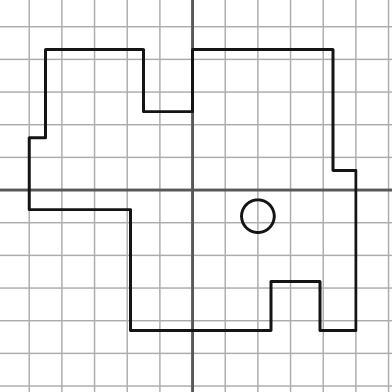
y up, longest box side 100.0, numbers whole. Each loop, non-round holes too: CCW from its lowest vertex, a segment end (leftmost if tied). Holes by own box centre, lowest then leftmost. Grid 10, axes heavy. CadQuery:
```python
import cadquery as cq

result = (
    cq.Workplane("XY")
    .moveTo(-19.0, -43.0)
    .lineTo(24.0, -43.0)
    .lineTo(24.0, -28.0)
    .lineTo(39.0, -28.0)
    .lineTo(39.0, -43.0)
    .lineTo(50.0, -43.0)
    .lineTo(50.0, 6.0)
    .lineTo(43.0, 6.0)
    .lineTo(43.0, 43.0)
    .lineTo(0.0, 43.0)
    .lineTo(0.0, 24.0)
    .lineTo(-15.0, 24.0)
    .lineTo(-15.0, 43.0)
    .lineTo(-45.0, 43.0)
    .lineTo(-45.0, 16.0)
    .lineTo(-50.0, 16.0)
    .lineTo(-50.0, -6.0)
    .lineTo(-19.0, -6.0)
    .close()
    .moveTo(20.0, -8.0)
    .circle(5.0)
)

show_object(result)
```